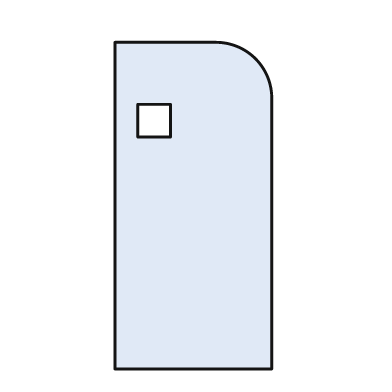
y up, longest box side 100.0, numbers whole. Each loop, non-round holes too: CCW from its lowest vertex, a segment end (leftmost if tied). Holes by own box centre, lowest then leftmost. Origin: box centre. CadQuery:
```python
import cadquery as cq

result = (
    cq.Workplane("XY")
    .moveTo(-24.0, -50.0)
    .lineTo(24.0, -50.0)
    .lineTo(24.0, 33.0)
    .threePointArc((19.0, 45.0), (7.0, 50.0))
    .lineTo(-24.0, 50.0)
    .close()
    .moveTo(-17.0, 21.0)
    .lineTo(-7.0, 21.0)
    .lineTo(-7.0, 31.0)
    .lineTo(-17.0, 31.0)
    .close()
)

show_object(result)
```